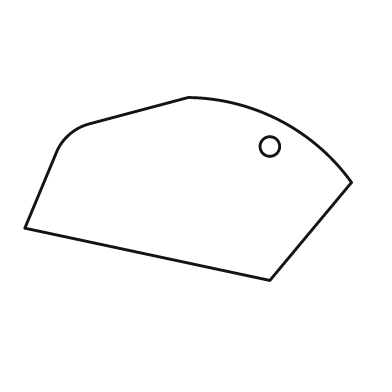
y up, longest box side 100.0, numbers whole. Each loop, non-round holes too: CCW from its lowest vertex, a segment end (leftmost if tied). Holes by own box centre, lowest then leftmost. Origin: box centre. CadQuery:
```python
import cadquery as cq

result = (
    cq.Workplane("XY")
    .moveTo(25.0, -28.0)
    .lineTo(50.0, 2.0)
    .threePointArc((28.0, 21.0), (0.0, 28.0))
    .lineTo(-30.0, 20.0)
    .threePointArc((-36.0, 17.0), (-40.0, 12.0))
    .lineTo(-50.0, -12.0)
    .close()
    .moveTo(25.0, 13.0)
    .circle(3.0)
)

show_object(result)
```